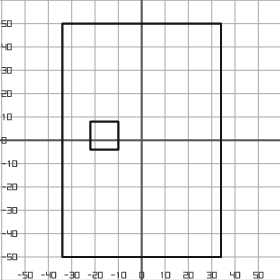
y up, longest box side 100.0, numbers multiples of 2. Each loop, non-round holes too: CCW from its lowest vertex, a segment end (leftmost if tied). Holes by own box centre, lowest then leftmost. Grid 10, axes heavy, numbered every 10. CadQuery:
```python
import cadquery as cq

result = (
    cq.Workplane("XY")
    .moveTo(-34.0, -50.0)
    .lineTo(34.0, -50.0)
    .lineTo(34.0, 50.0)
    .lineTo(-34.0, 50.0)
    .close()
    .moveTo(-22.0, -4.0)
    .lineTo(-10.0, -4.0)
    .lineTo(-10.0, 8.0)
    .lineTo(-22.0, 8.0)
    .close()
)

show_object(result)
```